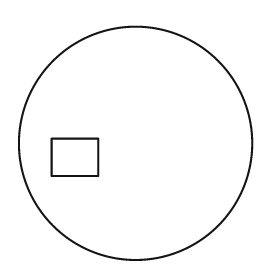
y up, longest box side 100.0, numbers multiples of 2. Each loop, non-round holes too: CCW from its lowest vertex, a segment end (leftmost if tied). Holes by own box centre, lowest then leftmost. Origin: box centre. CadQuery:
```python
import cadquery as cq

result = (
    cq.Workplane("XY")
    .moveTo(0.0, 0.0)
    .circle(50.0)
    .moveTo(-36.0, -14.0)
    .lineTo(-16.0, -14.0)
    .lineTo(-16.0, 2.0)
    .lineTo(-36.0, 2.0)
    .close()
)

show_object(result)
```